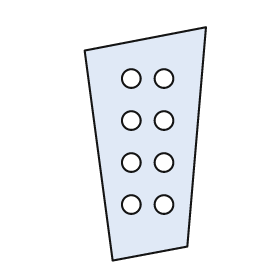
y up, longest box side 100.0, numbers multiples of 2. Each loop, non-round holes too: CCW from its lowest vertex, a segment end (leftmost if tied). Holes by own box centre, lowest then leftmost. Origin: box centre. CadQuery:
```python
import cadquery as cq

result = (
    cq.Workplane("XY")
    .moveTo(-14.0, -50.0)
    .lineTo(18.0, -44.0)
    .lineTo(26.0, 50.0)
    .lineTo(-26.0, 40.0)
    .close()
    .moveTo(-6.0, -26.0)
    .circle(4.0)
    .moveTo(8.0, -26.0)
    .circle(4.0)
    .moveTo(-6.0, -8.0)
    .circle(4.0)
    .moveTo(8.0, -8.0)
    .circle(4.0)
    .moveTo(-6.0, 10.0)
    .circle(4.0)
    .moveTo(8.0, 10.0)
    .circle(4.0)
    .moveTo(-6.0, 28.0)
    .circle(4.0)
    .moveTo(8.0, 28.0)
    .circle(4.0)
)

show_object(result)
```